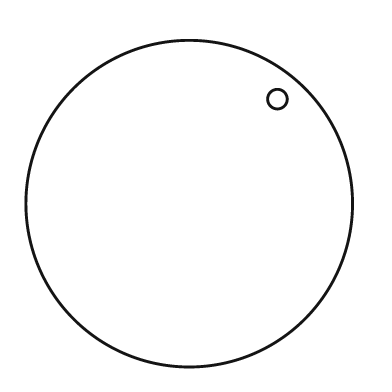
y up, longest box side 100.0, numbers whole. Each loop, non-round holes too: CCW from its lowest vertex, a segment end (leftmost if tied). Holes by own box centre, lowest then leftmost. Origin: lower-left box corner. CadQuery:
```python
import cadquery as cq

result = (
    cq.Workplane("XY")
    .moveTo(50.0, 50.0)
    .circle(50.0)
    .moveTo(77.0, 82.0)
    .circle(3.0)
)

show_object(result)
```